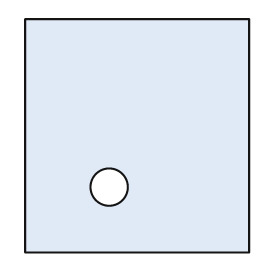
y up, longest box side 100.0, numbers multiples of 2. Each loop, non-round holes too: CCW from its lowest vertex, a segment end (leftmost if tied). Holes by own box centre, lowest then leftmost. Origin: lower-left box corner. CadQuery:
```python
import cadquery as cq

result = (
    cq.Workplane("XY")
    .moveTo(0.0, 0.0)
    .lineTo(96.0, 0.0)
    .lineTo(96.0, 100.0)
    .lineTo(0.0, 100.0)
    .close()
    .moveTo(36.0, 28.0)
    .circle(8.0)
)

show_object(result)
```